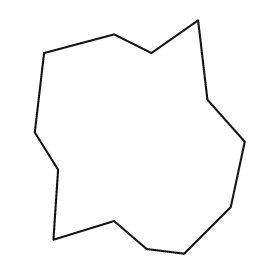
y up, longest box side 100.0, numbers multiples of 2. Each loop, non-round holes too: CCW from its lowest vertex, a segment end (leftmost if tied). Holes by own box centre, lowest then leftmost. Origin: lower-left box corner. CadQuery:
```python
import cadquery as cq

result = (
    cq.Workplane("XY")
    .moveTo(64.0, 0.0)
    .lineTo(84.0, 20.0)
    .lineTo(90.0, 48.0)
    .lineTo(74.0, 66.0)
    .lineTo(70.0, 100.0)
    .lineTo(50.0, 86.0)
    .lineTo(34.0, 94.0)
    .lineTo(4.0, 86.0)
    .lineTo(0.0, 52.0)
    .lineTo(10.0, 36.0)
    .lineTo(8.0, 6.0)
    .lineTo(34.0, 14.0)
    .lineTo(48.0, 2.0)
    .close()
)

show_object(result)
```